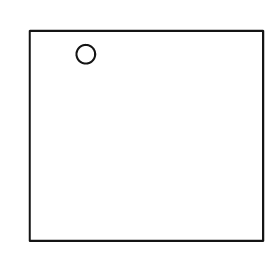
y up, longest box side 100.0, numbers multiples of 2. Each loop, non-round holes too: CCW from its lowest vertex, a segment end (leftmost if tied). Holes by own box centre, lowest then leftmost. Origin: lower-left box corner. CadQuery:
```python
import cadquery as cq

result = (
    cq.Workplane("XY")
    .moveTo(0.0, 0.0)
    .lineTo(100.0, 0.0)
    .lineTo(100.0, 90.0)
    .lineTo(0.0, 90.0)
    .close()
    .moveTo(24.0, 80.0)
    .circle(4.0)
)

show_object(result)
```